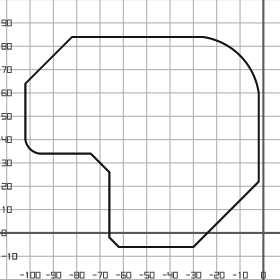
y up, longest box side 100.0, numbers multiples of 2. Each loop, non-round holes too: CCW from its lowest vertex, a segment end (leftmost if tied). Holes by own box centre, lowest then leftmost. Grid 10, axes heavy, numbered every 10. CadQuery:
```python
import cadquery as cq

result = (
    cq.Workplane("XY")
    .moveTo(-62.0, -6.0)
    .lineTo(-30.0, -6.0)
    .lineTo(-2.0, 22.0)
    .lineTo(-2.0, 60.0)
    .threePointArc((-10.0, 76.0), (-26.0, 84.0))
    .lineTo(-82.0, 84.0)
    .lineTo(-102.0, 64.0)
    .lineTo(-102.0, 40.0)
    .threePointArc((-100.0, 36.0), (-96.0, 34.0))
    .lineTo(-74.0, 34.0)
    .lineTo(-66.0, 26.0)
    .lineTo(-66.0, -2.0)
    .close()
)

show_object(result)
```